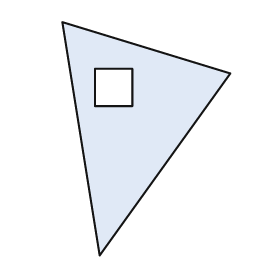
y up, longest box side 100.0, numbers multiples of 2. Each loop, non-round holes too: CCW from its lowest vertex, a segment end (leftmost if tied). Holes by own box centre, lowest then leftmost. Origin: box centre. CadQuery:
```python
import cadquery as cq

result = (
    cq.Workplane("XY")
    .moveTo(-20.0, -50.0)
    .lineTo(36.0, 28.0)
    .lineTo(-36.0, 50.0)
    .close()
    .moveTo(-22.0, 14.0)
    .lineTo(-6.0, 14.0)
    .lineTo(-6.0, 30.0)
    .lineTo(-22.0, 30.0)
    .close()
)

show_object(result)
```